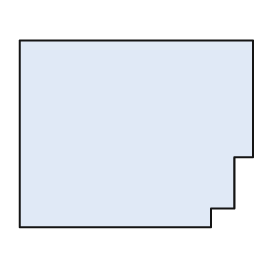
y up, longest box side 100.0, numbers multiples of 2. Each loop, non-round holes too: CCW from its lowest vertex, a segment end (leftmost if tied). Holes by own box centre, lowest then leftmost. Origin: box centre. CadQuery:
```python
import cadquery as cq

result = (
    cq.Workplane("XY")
    .moveTo(-50.0, -40.0)
    .lineTo(32.0, -40.0)
    .lineTo(32.0, -32.0)
    .lineTo(42.0, -32.0)
    .lineTo(42.0, -10.0)
    .lineTo(50.0, -10.0)
    .lineTo(50.0, 40.0)
    .lineTo(-50.0, 40.0)
    .close()
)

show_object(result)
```